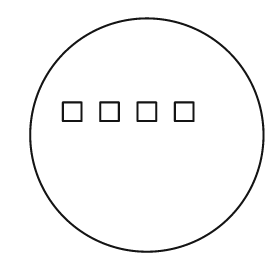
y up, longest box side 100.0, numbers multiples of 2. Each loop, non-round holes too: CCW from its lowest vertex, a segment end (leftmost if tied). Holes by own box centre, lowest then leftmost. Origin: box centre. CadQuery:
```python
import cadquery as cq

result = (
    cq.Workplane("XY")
    .moveTo(0.0, 0.0)
    .circle(50.0)
    .moveTo(-36.0, 6.0)
    .lineTo(-28.0, 6.0)
    .lineTo(-28.0, 14.0)
    .lineTo(-36.0, 14.0)
    .close()
    .moveTo(-20.0, 6.0)
    .lineTo(-12.0, 6.0)
    .lineTo(-12.0, 14.0)
    .lineTo(-20.0, 14.0)
    .close()
    .moveTo(-4.0, 6.0)
    .lineTo(4.0, 6.0)
    .lineTo(4.0, 14.0)
    .lineTo(-4.0, 14.0)
    .close()
    .moveTo(12.0, 6.0)
    .lineTo(20.0, 6.0)
    .lineTo(20.0, 14.0)
    .lineTo(12.0, 14.0)
    .close()
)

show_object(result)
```